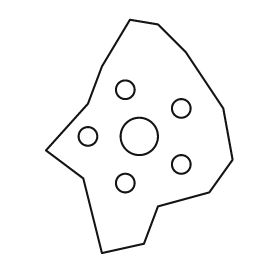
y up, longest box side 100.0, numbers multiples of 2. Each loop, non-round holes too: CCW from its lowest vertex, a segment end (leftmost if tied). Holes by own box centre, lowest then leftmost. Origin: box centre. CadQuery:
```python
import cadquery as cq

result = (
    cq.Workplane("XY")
    .moveTo(-16.0, -50.0)
    .lineTo(2.0, -46.0)
    .lineTo(8.0, -30.0)
    .lineTo(30.0, -24.0)
    .lineTo(40.0, -10.0)
    .lineTo(36.0, 12.0)
    .lineTo(20.0, 36.0)
    .lineTo(8.0, 48.0)
    .lineTo(-4.0, 50.0)
    .lineTo(-16.0, 30.0)
    .lineTo(-22.0, 14.0)
    .lineTo(-40.0, -6.0)
    .lineTo(-24.0, -18.0)
    .close()
    .moveTo(-6.0, -20.0)
    .circle(4.0)
    .moveTo(18.0, -12.0)
    .circle(4.0)
    .moveTo(-22.0, 0.0)
    .circle(4.0)
    .moveTo(0.0, 0.0)
    .circle(8.0)
    .moveTo(18.0, 12.0)
    .circle(4.0)
    .moveTo(-6.0, 20.0)
    .circle(4.0)
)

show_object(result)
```